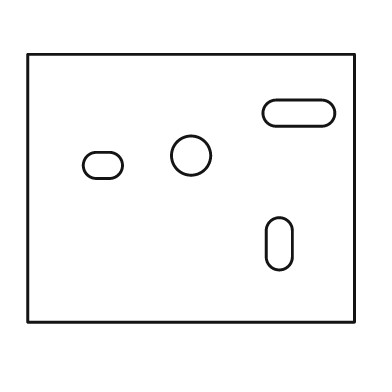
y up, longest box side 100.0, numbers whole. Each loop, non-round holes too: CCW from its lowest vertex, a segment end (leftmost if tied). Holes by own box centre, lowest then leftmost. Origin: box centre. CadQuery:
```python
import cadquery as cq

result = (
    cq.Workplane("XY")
    .moveTo(-50.0, -41.0)
    .lineTo(50.0, -41.0)
    .lineTo(50.0, 41.0)
    .lineTo(-50.0, 41.0)
    .close()
    .moveTo(23.0, -21.0)
    .threePointArc((27.0, -25.0), (31.0, -21.0))
    .lineTo(31.0, -13.0)
    .threePointArc((27.0, -9.0), (23.0, -13.0))
    .close()
    .moveTo(-29.0, 3.0)
    .lineTo(-25.0, 3.0)
    .threePointArc((-21.0, 7.0), (-25.0, 11.0))
    .lineTo(-29.0, 11.0)
    .threePointArc((-33.0, 7.0), (-29.0, 3.0))
    .close()
    .moveTo(0.0, 10.0)
    .circle(6.0)
    .moveTo(26.0, 19.0)
    .lineTo(40.0, 19.0)
    .threePointArc((44.0, 23.0), (40.0, 27.0))
    .lineTo(26.0, 27.0)
    .threePointArc((22.0, 23.0), (26.0, 19.0))
    .close()
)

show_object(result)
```